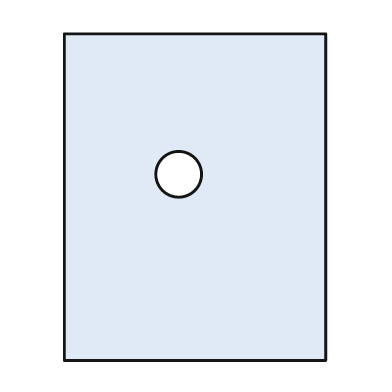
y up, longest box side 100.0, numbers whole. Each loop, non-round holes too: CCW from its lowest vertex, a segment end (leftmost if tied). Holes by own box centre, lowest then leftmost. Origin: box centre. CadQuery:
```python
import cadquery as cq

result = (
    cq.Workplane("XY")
    .moveTo(-40.0, -50.0)
    .lineTo(40.0, -50.0)
    .lineTo(40.0, 50.0)
    .lineTo(-40.0, 50.0)
    .close()
    .moveTo(-5.0, 7.0)
    .circle(7.0)
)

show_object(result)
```